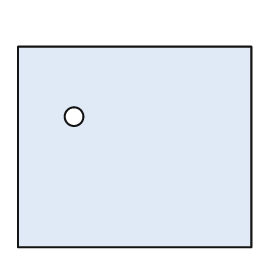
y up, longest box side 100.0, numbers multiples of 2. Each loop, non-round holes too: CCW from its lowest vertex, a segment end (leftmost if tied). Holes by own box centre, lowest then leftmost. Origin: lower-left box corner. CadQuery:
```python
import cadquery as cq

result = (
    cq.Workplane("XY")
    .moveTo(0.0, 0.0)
    .lineTo(100.0, 0.0)
    .lineTo(100.0, 86.0)
    .lineTo(0.0, 86.0)
    .close()
    .moveTo(24.0, 56.0)
    .circle(4.0)
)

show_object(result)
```